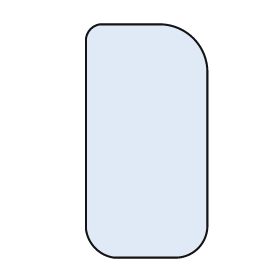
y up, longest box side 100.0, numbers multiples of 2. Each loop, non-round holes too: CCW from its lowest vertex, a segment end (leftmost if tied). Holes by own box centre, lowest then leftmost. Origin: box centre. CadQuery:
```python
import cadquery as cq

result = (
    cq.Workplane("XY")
    .moveTo(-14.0, -50.0)
    .lineTo(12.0, -50.0)
    .threePointArc((22.0, -46.0), (26.0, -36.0))
    .lineTo(26.0, 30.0)
    .threePointArc((20.0, 44.0), (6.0, 50.0))
    .lineTo(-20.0, 50.0)
    .threePointArc((-24.0, 48.0), (-26.0, 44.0))
    .lineTo(-26.0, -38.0)
    .threePointArc((-22.0, -46.0), (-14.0, -50.0))
    .close()
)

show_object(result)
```